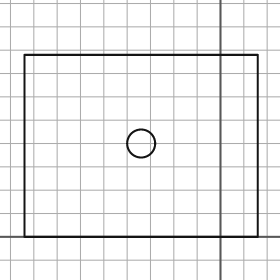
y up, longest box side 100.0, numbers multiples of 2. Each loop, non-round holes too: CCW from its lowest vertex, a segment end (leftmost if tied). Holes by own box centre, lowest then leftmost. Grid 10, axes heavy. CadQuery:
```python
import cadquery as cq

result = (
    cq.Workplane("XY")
    .moveTo(-84.0, 0.0)
    .lineTo(16.0, 0.0)
    .lineTo(16.0, 78.0)
    .lineTo(-84.0, 78.0)
    .close()
    .moveTo(-34.0, 40.0)
    .circle(6.0)
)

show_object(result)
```